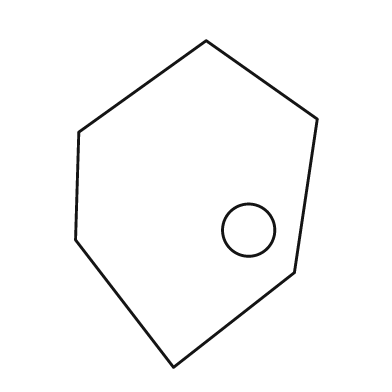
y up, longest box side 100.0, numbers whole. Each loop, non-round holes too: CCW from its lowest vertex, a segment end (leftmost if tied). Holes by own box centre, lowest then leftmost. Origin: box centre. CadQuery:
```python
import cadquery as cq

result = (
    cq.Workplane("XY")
    .moveTo(-7.0, -50.0)
    .lineTo(30.0, -21.0)
    .lineTo(37.0, 26.0)
    .lineTo(3.0, 50.0)
    .lineTo(-36.0, 22.0)
    .lineTo(-37.0, -11.0)
    .close()
    .moveTo(16.0, -8.0)
    .circle(8.0)
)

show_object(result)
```